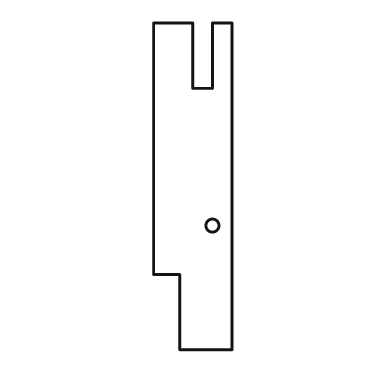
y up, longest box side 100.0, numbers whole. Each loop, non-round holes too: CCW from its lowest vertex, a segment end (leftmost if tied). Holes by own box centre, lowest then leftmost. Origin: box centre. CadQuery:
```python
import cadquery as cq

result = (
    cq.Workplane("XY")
    .moveTo(-4.0, -50.0)
    .lineTo(12.0, -50.0)
    .lineTo(12.0, 50.0)
    .lineTo(6.0, 50.0)
    .lineTo(6.0, 30.0)
    .lineTo(0.0, 30.0)
    .lineTo(0.0, 50.0)
    .lineTo(-12.0, 50.0)
    .lineTo(-12.0, -27.0)
    .lineTo(-4.0, -27.0)
    .close()
    .moveTo(6.0, -12.0)
    .circle(2.0)
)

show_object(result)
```